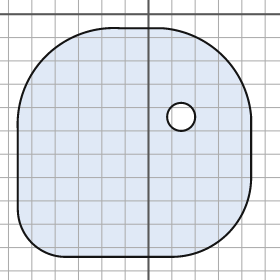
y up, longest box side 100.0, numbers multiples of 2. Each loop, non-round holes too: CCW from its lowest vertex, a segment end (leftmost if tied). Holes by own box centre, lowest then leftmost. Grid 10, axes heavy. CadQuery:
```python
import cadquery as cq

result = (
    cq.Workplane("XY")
    .moveTo(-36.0, -104.0)
    .lineTo(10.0, -104.0)
    .threePointArc((34.0, -94.0), (44.0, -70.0))
    .lineTo(44.0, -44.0)
    .threePointArc((32.0, -18.0), (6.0, -6.0))
    .lineTo(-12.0, -6.0)
    .threePointArc((-44.0, -18.0), (-56.0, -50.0))
    .lineTo(-56.0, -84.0)
    .threePointArc((-50.0, -98.0), (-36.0, -104.0))
    .close()
    .moveTo(14.0, -44.0)
    .circle(6.0)
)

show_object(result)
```